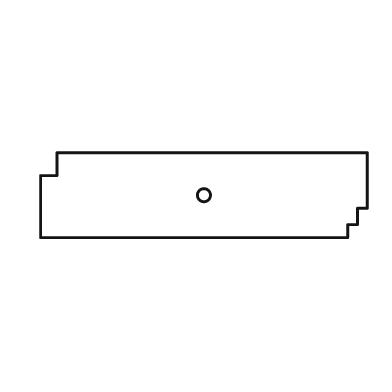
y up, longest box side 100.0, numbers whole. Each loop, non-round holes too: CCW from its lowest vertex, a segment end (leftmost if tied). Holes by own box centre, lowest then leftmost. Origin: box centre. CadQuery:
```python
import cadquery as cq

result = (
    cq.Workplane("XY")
    .moveTo(-50.0, -13.0)
    .lineTo(44.0, -13.0)
    .lineTo(44.0, -9.0)
    .lineTo(47.0, -9.0)
    .lineTo(47.0, -4.0)
    .lineTo(50.0, -4.0)
    .lineTo(50.0, 13.0)
    .lineTo(-45.0, 13.0)
    .lineTo(-45.0, 6.0)
    .lineTo(-50.0, 6.0)
    .close()
    .moveTo(0.0, 0.0)
    .circle(2.0)
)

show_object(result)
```